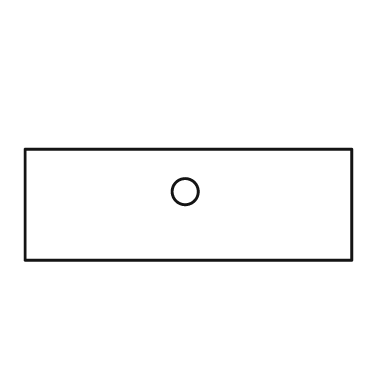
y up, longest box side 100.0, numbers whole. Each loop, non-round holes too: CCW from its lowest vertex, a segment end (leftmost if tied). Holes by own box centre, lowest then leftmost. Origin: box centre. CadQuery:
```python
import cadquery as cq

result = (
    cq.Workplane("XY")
    .moveTo(-50.0, -17.0)
    .lineTo(50.0, -17.0)
    .lineTo(50.0, 17.0)
    .lineTo(-50.0, 17.0)
    .close()
    .moveTo(-1.0, 4.0)
    .circle(4.0)
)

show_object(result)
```